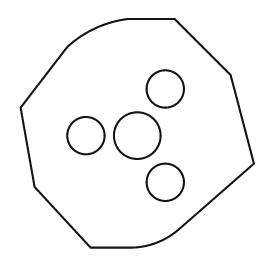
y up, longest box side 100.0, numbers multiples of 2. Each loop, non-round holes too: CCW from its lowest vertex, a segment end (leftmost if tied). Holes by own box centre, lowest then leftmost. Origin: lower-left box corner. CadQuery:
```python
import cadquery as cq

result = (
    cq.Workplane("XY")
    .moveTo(30.0, 0.0)
    .lineTo(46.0, 0.0)
    .threePointArc((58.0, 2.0), (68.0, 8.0))
    .lineTo(100.0, 36.0)
    .lineTo(90.0, 74.0)
    .lineTo(66.0, 98.0)
    .lineTo(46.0, 98.0)
    .threePointArc((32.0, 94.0), (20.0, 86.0))
    .lineTo(0.0, 60.0)
    .lineTo(6.0, 26.0)
    .close()
    .moveTo(62.0, 28.0)
    .circle(8.0)
    .moveTo(28.0, 48.0)
    .circle(8.0)
    .moveTo(50.0, 48.0)
    .circle(10.0)
    .moveTo(62.0, 68.0)
    .circle(8.0)
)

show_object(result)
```